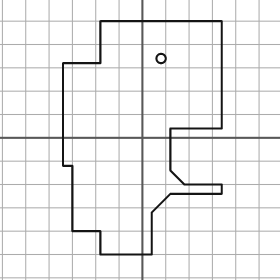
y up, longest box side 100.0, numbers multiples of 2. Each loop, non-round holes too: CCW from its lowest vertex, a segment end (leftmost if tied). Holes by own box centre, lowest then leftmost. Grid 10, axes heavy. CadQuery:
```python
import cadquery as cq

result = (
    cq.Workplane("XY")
    .moveTo(-18.0, -50.0)
    .lineTo(4.0, -50.0)
    .lineTo(4.0, -32.0)
    .lineTo(12.0, -24.0)
    .lineTo(34.0, -24.0)
    .lineTo(34.0, -20.0)
    .lineTo(18.0, -20.0)
    .lineTo(12.0, -14.0)
    .lineTo(12.0, 4.0)
    .lineTo(34.0, 4.0)
    .lineTo(34.0, 50.0)
    .lineTo(-18.0, 50.0)
    .lineTo(-18.0, 32.0)
    .lineTo(-34.0, 32.0)
    .lineTo(-34.0, -12.0)
    .lineTo(-30.0, -12.0)
    .lineTo(-30.0, -40.0)
    .lineTo(-18.0, -40.0)
    .close()
    .moveTo(8.0, 34.0)
    .circle(2.0)
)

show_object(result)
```